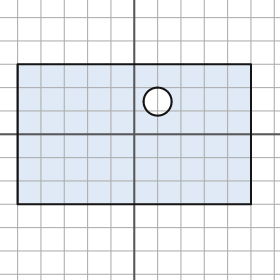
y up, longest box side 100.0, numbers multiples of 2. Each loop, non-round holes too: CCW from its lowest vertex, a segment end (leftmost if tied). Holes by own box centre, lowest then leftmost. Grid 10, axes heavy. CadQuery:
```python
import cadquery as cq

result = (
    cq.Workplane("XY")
    .moveTo(-50.0, -30.0)
    .lineTo(50.0, -30.0)
    .lineTo(50.0, 30.0)
    .lineTo(-50.0, 30.0)
    .close()
    .moveTo(10.0, 14.0)
    .circle(6.0)
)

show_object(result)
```